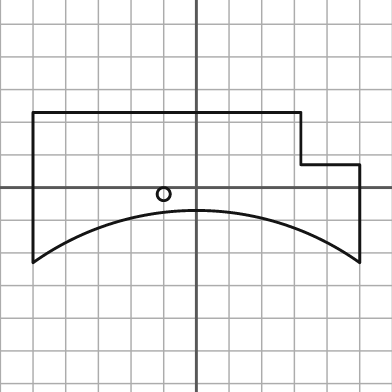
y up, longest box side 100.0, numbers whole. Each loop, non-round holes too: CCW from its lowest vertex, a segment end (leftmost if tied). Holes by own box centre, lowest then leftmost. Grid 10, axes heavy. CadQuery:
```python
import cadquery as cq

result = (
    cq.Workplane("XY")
    .moveTo(-50.0, -23.0)
    .threePointArc((0.0, -7.0), (50.0, -23.0))
    .lineTo(50.0, 7.0)
    .lineTo(32.0, 7.0)
    .lineTo(32.0, 23.0)
    .lineTo(-50.0, 23.0)
    .close()
    .moveTo(-10.0, -2.0)
    .circle(2.0)
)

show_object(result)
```